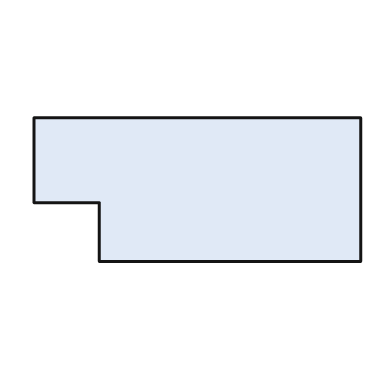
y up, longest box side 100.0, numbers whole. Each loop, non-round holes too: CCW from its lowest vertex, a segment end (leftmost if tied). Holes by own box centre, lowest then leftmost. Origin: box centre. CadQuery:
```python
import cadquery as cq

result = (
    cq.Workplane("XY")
    .moveTo(-30.0, -22.0)
    .lineTo(50.0, -22.0)
    .lineTo(50.0, 22.0)
    .lineTo(-50.0, 22.0)
    .lineTo(-50.0, -4.0)
    .lineTo(-30.0, -4.0)
    .close()
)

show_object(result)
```